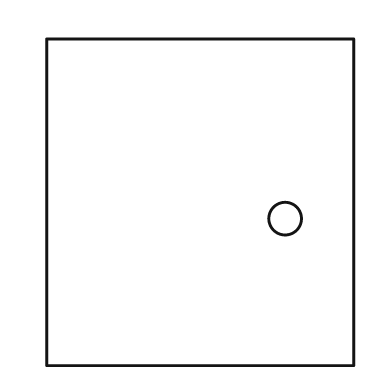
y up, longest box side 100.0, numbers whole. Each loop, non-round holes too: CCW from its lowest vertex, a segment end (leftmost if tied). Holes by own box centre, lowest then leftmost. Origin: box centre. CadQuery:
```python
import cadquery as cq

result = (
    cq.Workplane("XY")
    .moveTo(-47.0, -50.0)
    .lineTo(47.0, -50.0)
    .lineTo(47.0, 50.0)
    .lineTo(-47.0, 50.0)
    .close()
    .moveTo(26.0, -5.0)
    .circle(5.0)
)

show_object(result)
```